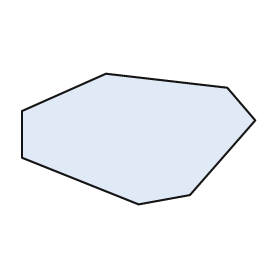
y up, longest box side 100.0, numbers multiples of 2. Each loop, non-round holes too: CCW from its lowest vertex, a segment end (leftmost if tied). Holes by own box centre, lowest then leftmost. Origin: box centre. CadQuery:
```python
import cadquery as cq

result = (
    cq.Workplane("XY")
    .moveTo(0.0, -28.0)
    .lineTo(22.0, -24.0)
    .lineTo(50.0, 8.0)
    .lineTo(38.0, 22.0)
    .lineTo(-14.0, 28.0)
    .lineTo(-50.0, 12.0)
    .lineTo(-50.0, -8.0)
    .close()
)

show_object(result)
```